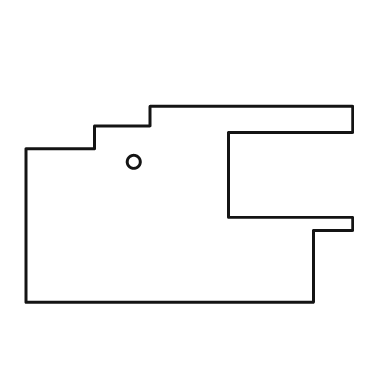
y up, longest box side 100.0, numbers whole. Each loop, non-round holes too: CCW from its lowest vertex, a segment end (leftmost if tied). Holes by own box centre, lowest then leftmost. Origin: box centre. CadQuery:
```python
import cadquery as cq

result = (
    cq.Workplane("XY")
    .moveTo(-50.0, -30.0)
    .lineTo(38.0, -30.0)
    .lineTo(38.0, -8.0)
    .lineTo(50.0, -8.0)
    .lineTo(50.0, -4.0)
    .lineTo(12.0, -4.0)
    .lineTo(12.0, 22.0)
    .lineTo(50.0, 22.0)
    .lineTo(50.0, 30.0)
    .lineTo(-12.0, 30.0)
    .lineTo(-12.0, 24.0)
    .lineTo(-29.0, 24.0)
    .lineTo(-29.0, 17.0)
    .lineTo(-50.0, 17.0)
    .close()
    .moveTo(-17.0, 13.0)
    .circle(2.0)
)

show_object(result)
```